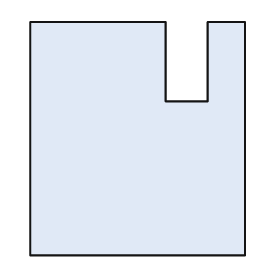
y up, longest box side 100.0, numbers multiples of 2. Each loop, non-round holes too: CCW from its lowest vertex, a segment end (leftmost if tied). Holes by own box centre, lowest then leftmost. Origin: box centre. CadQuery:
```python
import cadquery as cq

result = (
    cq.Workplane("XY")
    .moveTo(-46.0, -50.0)
    .lineTo(46.0, -50.0)
    .lineTo(46.0, 50.0)
    .lineTo(30.0, 50.0)
    .lineTo(30.0, 16.0)
    .lineTo(12.0, 16.0)
    .lineTo(12.0, 50.0)
    .lineTo(-46.0, 50.0)
    .close()
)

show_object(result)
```